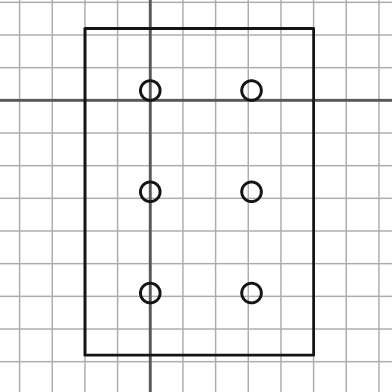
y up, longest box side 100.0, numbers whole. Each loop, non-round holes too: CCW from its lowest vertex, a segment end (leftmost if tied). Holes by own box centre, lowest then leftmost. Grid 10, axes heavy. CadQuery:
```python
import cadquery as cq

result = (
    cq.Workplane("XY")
    .moveTo(-20.0, -78.0)
    .lineTo(50.0, -78.0)
    .lineTo(50.0, 22.0)
    .lineTo(-20.0, 22.0)
    .close()
    .moveTo(0.0, -59.0)
    .circle(3.0)
    .moveTo(31.0, -59.0)
    .circle(3.0)
    .moveTo(0.0, -28.0)
    .circle(3.0)
    .moveTo(31.0, -28.0)
    .circle(3.0)
    .moveTo(0.0, 3.0)
    .circle(3.0)
    .moveTo(31.0, 3.0)
    .circle(3.0)
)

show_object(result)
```